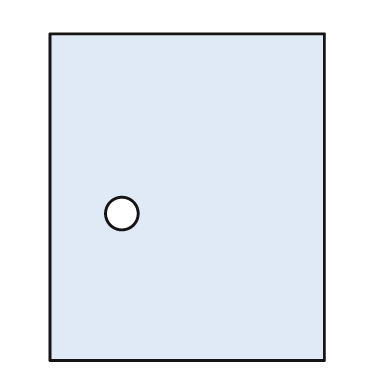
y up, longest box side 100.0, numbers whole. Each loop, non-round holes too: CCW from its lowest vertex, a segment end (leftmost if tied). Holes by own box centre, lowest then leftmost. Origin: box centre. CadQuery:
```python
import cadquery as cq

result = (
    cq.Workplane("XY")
    .moveTo(-42.0, -50.0)
    .lineTo(42.0, -50.0)
    .lineTo(42.0, 50.0)
    .lineTo(-42.0, 50.0)
    .close()
    .moveTo(-20.0, -5.0)
    .circle(5.0)
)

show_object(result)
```